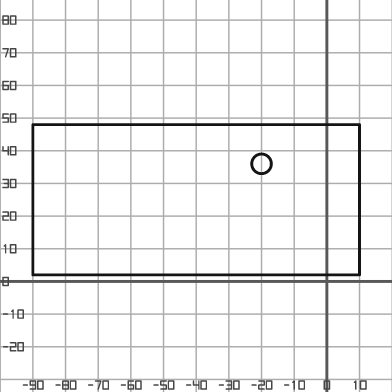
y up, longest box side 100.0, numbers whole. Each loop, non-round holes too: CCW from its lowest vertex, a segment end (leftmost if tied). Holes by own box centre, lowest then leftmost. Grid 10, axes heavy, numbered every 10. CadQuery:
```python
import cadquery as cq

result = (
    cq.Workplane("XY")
    .moveTo(-90.0, 2.0)
    .lineTo(10.0, 2.0)
    .lineTo(10.0, 48.0)
    .lineTo(-90.0, 48.0)
    .close()
    .moveTo(-20.0, 36.0)
    .circle(3.0)
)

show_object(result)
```